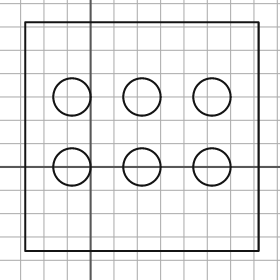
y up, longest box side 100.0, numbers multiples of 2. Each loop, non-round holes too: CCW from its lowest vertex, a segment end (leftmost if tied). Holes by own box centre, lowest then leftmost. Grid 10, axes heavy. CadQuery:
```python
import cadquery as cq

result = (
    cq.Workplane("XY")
    .moveTo(-28.0, -36.0)
    .lineTo(72.0, -36.0)
    .lineTo(72.0, 62.0)
    .lineTo(-28.0, 62.0)
    .close()
    .moveTo(-8.0, 0.0)
    .circle(8.0)
    .moveTo(22.0, 0.0)
    .circle(8.0)
    .moveTo(52.0, 0.0)
    .circle(8.0)
    .moveTo(-8.0, 30.0)
    .circle(8.0)
    .moveTo(22.0, 30.0)
    .circle(8.0)
    .moveTo(52.0, 30.0)
    .circle(8.0)
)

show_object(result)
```